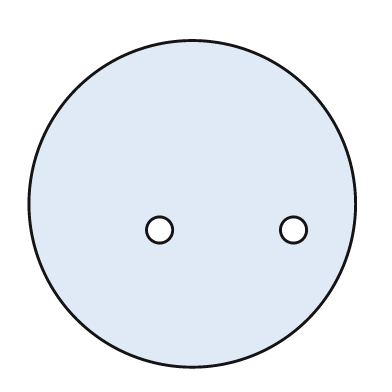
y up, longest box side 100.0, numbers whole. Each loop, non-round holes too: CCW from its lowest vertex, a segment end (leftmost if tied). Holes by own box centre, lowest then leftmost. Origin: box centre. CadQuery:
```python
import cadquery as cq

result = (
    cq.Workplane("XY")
    .moveTo(0.0, 0.0)
    .circle(50.0)
    .moveTo(-10.0, -8.0)
    .circle(4.0)
    .moveTo(31.0, -8.0)
    .circle(4.0)
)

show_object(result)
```